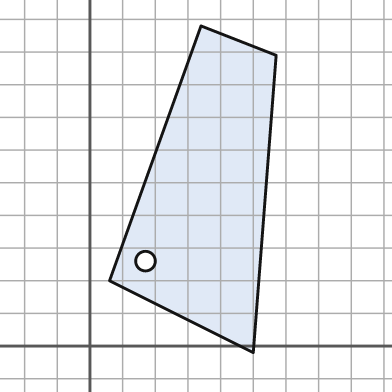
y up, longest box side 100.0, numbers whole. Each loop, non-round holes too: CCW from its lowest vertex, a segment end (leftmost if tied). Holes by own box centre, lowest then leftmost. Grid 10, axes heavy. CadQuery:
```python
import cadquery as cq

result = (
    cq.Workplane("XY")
    .moveTo(50.0, -2.0)
    .lineTo(57.0, 89.0)
    .lineTo(34.0, 98.0)
    .lineTo(6.0, 20.0)
    .close()
    .moveTo(17.0, 26.0)
    .circle(3.0)
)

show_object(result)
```